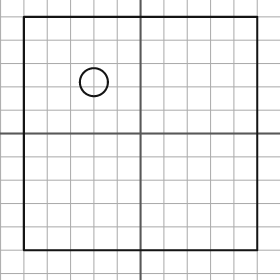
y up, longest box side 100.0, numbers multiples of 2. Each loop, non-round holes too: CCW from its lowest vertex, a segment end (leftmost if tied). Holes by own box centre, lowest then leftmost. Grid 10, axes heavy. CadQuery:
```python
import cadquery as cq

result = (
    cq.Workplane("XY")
    .moveTo(-50.0, -50.0)
    .lineTo(50.0, -50.0)
    .lineTo(50.0, 50.0)
    .lineTo(-50.0, 50.0)
    .close()
    .moveTo(-20.0, 22.0)
    .circle(6.0)
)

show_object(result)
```